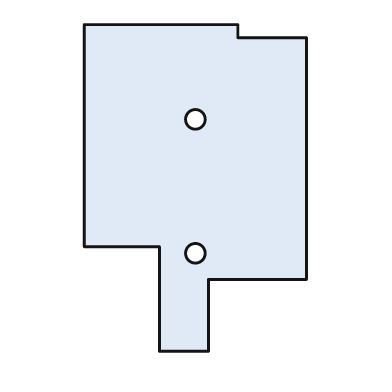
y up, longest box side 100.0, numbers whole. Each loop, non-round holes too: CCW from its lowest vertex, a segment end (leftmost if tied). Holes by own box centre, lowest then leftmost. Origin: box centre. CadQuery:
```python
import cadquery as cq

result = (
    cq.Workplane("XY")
    .moveTo(-11.0, -50.0)
    .lineTo(4.0, -50.0)
    .lineTo(4.0, -28.0)
    .lineTo(34.0, -28.0)
    .lineTo(34.0, 46.0)
    .lineTo(13.0, 46.0)
    .lineTo(13.0, 50.0)
    .lineTo(-34.0, 50.0)
    .lineTo(-34.0, -18.0)
    .lineTo(-11.0, -18.0)
    .close()
    .moveTo(0.0, -20.0)
    .circle(3.0)
    .moveTo(0.0, 21.0)
    .circle(3.0)
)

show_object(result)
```